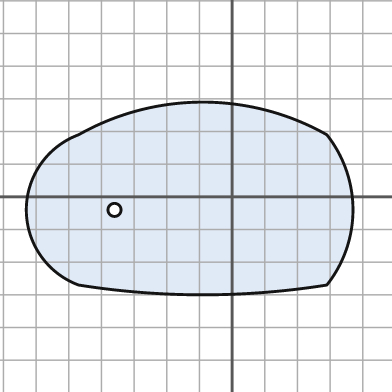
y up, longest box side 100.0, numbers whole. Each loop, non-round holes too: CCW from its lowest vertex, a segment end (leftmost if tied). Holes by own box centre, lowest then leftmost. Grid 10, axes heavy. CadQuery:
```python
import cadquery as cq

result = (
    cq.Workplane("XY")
    .moveTo(-47.0, -27.0)
    .threePointArc((-9.0, -30.0), (29.0, -27.0))
    .threePointArc((37.0, -4.0), (29.0, 19.0))
    .threePointArc((-9.0, 29.0), (-47.0, 19.0))
    .threePointArc((-63.0, -4.0), (-47.0, -27.0))
    .close()
    .moveTo(-36.0, -4.0)
    .circle(2.0)
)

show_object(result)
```